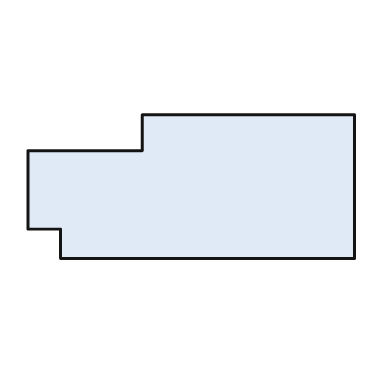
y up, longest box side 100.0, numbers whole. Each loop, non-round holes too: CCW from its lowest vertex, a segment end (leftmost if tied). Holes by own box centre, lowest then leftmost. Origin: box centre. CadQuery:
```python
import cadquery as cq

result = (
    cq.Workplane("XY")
    .moveTo(-40.0, -22.0)
    .lineTo(50.0, -22.0)
    .lineTo(50.0, 22.0)
    .lineTo(-15.0, 22.0)
    .lineTo(-15.0, 11.0)
    .lineTo(-50.0, 11.0)
    .lineTo(-50.0, -13.0)
    .lineTo(-40.0, -13.0)
    .close()
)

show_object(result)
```